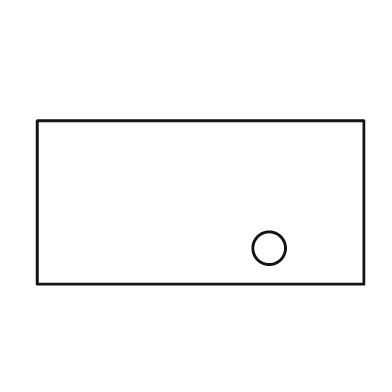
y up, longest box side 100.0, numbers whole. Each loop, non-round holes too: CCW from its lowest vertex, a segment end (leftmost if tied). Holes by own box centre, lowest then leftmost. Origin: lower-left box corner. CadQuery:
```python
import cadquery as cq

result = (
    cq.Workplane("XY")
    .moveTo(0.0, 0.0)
    .lineTo(100.0, 0.0)
    .lineTo(100.0, 50.0)
    .lineTo(0.0, 50.0)
    .close()
    .moveTo(71.0, 11.0)
    .circle(5.0)
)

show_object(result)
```